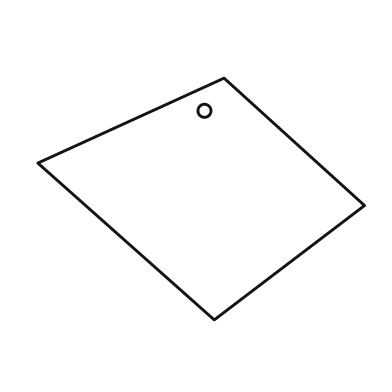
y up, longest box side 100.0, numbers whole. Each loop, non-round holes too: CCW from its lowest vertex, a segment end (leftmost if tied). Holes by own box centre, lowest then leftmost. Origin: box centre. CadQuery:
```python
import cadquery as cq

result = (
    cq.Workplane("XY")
    .moveTo(4.0, -37.0)
    .lineTo(50.0, -2.0)
    .lineTo(7.0, 37.0)
    .lineTo(-50.0, 11.0)
    .close()
    .moveTo(1.0, 27.0)
    .circle(2.0)
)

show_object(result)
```